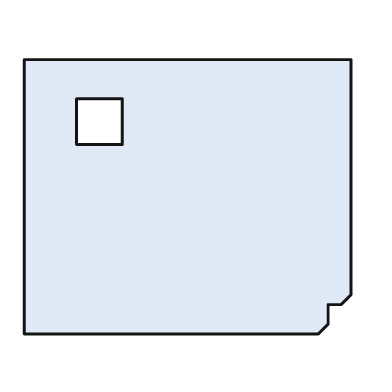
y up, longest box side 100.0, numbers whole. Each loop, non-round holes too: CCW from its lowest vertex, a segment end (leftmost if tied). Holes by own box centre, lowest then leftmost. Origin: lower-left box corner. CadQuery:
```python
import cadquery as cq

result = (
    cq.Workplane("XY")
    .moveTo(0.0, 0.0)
    .lineTo(90.0, 0.0)
    .lineTo(93.0, 3.0)
    .lineTo(93.0, 9.0)
    .lineTo(97.0, 9.0)
    .lineTo(100.0, 12.0)
    .lineTo(100.0, 84.0)
    .lineTo(0.0, 84.0)
    .close()
    .moveTo(16.0, 58.0)
    .lineTo(30.0, 58.0)
    .lineTo(30.0, 72.0)
    .lineTo(16.0, 72.0)
    .close()
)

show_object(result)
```